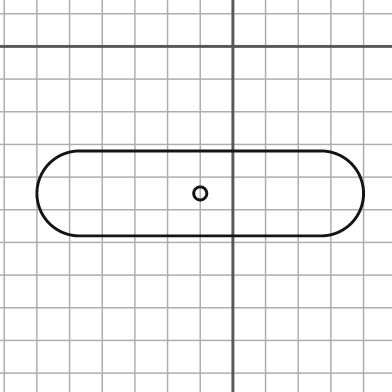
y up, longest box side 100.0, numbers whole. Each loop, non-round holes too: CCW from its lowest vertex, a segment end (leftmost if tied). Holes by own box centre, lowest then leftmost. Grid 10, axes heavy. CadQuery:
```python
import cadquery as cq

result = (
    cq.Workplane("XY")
    .moveTo(-47.0, -58.0)
    .lineTo(27.0, -58.0)
    .threePointArc((40.0, -45.0), (27.0, -32.0))
    .lineTo(-47.0, -32.0)
    .threePointArc((-60.0, -45.0), (-47.0, -58.0))
    .close()
    .moveTo(-10.0, -45.0)
    .circle(2.0)
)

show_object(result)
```